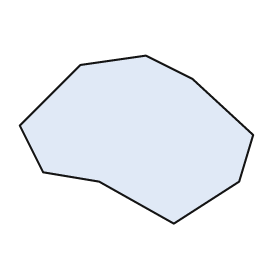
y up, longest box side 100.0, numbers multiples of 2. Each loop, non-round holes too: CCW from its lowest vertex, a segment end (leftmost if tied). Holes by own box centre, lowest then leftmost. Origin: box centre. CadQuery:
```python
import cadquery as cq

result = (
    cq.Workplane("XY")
    .moveTo(16.0, -36.0)
    .lineTo(44.0, -18.0)
    .lineTo(50.0, 2.0)
    .lineTo(24.0, 26.0)
    .lineTo(4.0, 36.0)
    .lineTo(-24.0, 32.0)
    .lineTo(-50.0, 6.0)
    .lineTo(-40.0, -14.0)
    .lineTo(-16.0, -18.0)
    .close()
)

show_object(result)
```